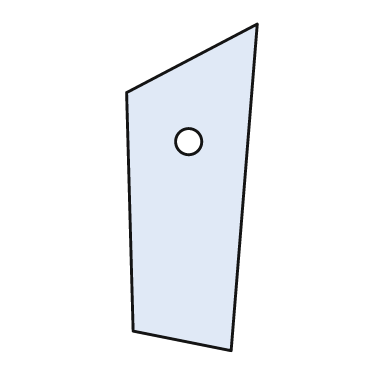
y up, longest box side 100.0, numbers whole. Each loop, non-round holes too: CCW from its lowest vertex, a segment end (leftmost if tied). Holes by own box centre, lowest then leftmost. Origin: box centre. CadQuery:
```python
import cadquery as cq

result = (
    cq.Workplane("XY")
    .moveTo(12.0, -50.0)
    .lineTo(20.0, 50.0)
    .lineTo(-20.0, 29.0)
    .lineTo(-18.0, -44.0)
    .close()
    .moveTo(-1.0, 14.0)
    .circle(4.0)
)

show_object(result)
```